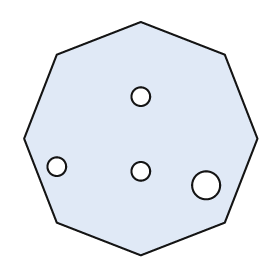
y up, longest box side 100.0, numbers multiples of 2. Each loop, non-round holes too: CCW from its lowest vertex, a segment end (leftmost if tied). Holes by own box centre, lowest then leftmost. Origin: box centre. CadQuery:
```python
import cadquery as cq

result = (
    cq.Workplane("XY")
    .moveTo(0.0, -50.0)
    .lineTo(36.0, -36.0)
    .lineTo(50.0, 0.0)
    .lineTo(36.0, 36.0)
    .lineTo(0.0, 50.0)
    .lineTo(-36.0, 36.0)
    .lineTo(-50.0, 0.0)
    .lineTo(-36.0, -36.0)
    .close()
    .moveTo(28.0, -20.0)
    .circle(6.0)
    .moveTo(0.0, -14.0)
    .circle(4.0)
    .moveTo(-36.0, -12.0)
    .circle(4.0)
    .moveTo(0.0, 18.0)
    .circle(4.0)
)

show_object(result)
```